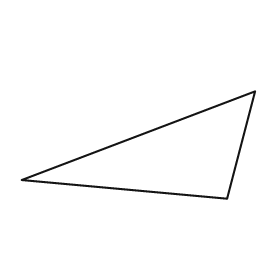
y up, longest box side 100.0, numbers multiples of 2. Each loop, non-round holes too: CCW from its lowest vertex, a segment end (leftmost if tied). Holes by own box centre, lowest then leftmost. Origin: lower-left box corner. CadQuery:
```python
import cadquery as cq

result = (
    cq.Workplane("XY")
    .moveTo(88.0, 0.0)
    .lineTo(100.0, 46.0)
    .lineTo(0.0, 8.0)
    .close()
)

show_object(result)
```